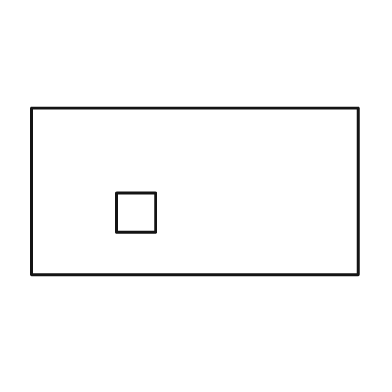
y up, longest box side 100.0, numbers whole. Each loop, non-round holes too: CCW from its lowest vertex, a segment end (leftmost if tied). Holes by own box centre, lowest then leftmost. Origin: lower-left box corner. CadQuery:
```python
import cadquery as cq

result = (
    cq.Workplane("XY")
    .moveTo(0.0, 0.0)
    .lineTo(100.0, 0.0)
    .lineTo(100.0, 51.0)
    .lineTo(0.0, 51.0)
    .close()
    .moveTo(26.0, 13.0)
    .lineTo(38.0, 13.0)
    .lineTo(38.0, 25.0)
    .lineTo(26.0, 25.0)
    .close()
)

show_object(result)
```